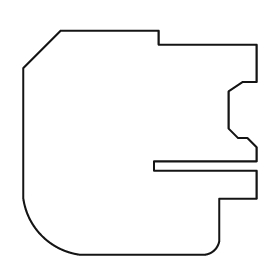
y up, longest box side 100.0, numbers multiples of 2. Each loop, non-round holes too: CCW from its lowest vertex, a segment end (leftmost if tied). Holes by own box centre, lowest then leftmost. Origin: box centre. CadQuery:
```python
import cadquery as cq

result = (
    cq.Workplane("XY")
    .moveTo(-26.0, -48.0)
    .lineTo(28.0, -48.0)
    .threePointArc((32.0, -46.0), (34.0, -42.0))
    .lineTo(34.0, -24.0)
    .lineTo(50.0, -24.0)
    .lineTo(50.0, -12.0)
    .lineTo(6.0, -12.0)
    .lineTo(6.0, -8.0)
    .lineTo(50.0, -8.0)
    .lineTo(50.0, -2.0)
    .lineTo(46.0, 2.0)
    .lineTo(42.0, 2.0)
    .lineTo(38.0, 6.0)
    .lineTo(38.0, 22.0)
    .lineTo(44.0, 26.0)
    .lineTo(50.0, 26.0)
    .lineTo(50.0, 42.0)
    .lineTo(8.0, 42.0)
    .lineTo(8.0, 48.0)
    .lineTo(-34.0, 48.0)
    .lineTo(-50.0, 32.0)
    .lineTo(-50.0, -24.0)
    .threePointArc((-42.0, -40.0), (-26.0, -48.0))
    .close()
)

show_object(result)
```